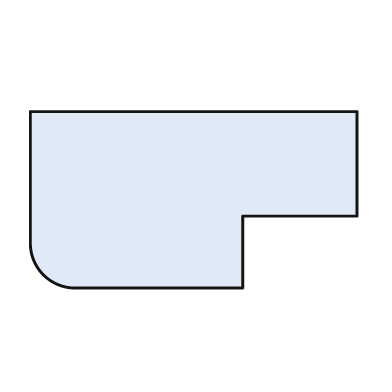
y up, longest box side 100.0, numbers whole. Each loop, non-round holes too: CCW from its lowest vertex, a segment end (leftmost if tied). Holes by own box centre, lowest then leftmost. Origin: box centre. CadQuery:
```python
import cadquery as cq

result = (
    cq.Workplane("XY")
    .moveTo(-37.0, -27.0)
    .lineTo(15.0, -27.0)
    .lineTo(15.0, -5.0)
    .lineTo(50.0, -5.0)
    .lineTo(50.0, 27.0)
    .lineTo(-50.0, 27.0)
    .lineTo(-50.0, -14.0)
    .threePointArc((-46.0, -23.0), (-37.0, -27.0))
    .close()
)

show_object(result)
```